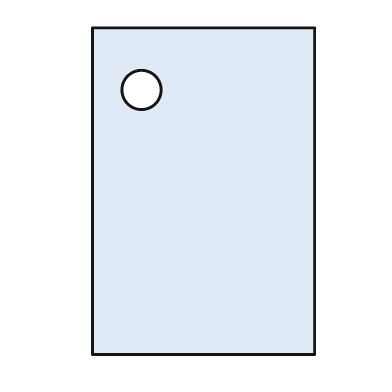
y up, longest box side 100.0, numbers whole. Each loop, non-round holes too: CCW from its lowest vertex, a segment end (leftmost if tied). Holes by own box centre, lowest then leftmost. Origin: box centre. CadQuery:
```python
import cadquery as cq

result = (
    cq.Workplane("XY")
    .moveTo(-34.0, -50.0)
    .lineTo(34.0, -50.0)
    .lineTo(34.0, 50.0)
    .lineTo(-34.0, 50.0)
    .close()
    .moveTo(-19.0, 31.0)
    .circle(6.0)
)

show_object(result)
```